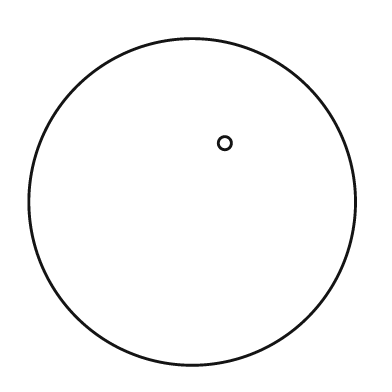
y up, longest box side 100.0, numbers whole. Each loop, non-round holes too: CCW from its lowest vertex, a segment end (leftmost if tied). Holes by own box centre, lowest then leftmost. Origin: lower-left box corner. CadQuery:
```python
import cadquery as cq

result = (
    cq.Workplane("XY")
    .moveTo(50.0, 50.0)
    .circle(50.0)
    .moveTo(60.0, 68.0)
    .circle(2.0)
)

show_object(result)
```